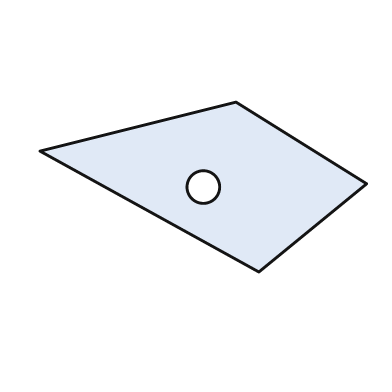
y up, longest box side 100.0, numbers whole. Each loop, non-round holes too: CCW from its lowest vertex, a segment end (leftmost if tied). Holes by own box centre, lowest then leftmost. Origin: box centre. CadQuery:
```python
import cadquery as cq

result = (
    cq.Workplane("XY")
    .moveTo(17.0, -26.0)
    .lineTo(50.0, 1.0)
    .lineTo(10.0, 26.0)
    .lineTo(-50.0, 11.0)
    .close()
    .moveTo(0.0, 0.0)
    .circle(5.0)
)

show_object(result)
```